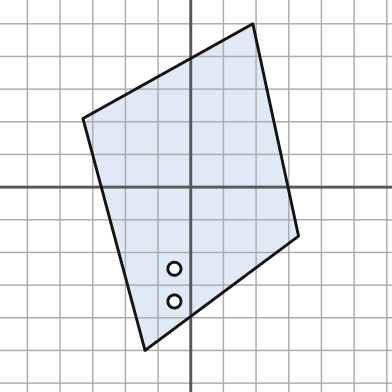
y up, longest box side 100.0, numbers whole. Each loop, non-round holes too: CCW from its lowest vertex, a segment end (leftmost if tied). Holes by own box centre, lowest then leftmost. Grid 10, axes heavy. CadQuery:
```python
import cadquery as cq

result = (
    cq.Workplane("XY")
    .moveTo(-14.0, -50.0)
    .lineTo(33.0, -15.0)
    .lineTo(19.0, 50.0)
    .lineTo(-33.0, 21.0)
    .close()
    .moveTo(-5.0, -35.0)
    .circle(2.0)
    .moveTo(-5.0, -25.0)
    .circle(2.0)
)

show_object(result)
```